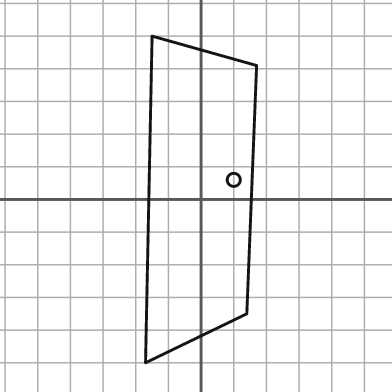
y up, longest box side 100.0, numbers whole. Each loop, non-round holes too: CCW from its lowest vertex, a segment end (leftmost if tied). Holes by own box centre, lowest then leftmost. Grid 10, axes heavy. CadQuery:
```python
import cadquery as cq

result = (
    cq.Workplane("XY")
    .moveTo(-17.0, -50.0)
    .lineTo(14.0, -35.0)
    .lineTo(17.0, 41.0)
    .lineTo(-15.0, 50.0)
    .close()
    .moveTo(10.0, 6.0)
    .circle(2.0)
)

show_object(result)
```